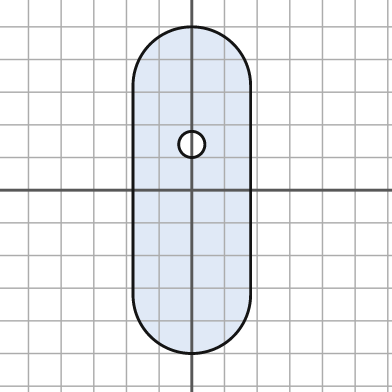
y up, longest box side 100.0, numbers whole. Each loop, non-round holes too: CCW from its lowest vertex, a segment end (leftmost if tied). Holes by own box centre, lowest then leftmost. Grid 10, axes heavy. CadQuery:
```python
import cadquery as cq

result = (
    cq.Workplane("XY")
    .moveTo(-18.0, -32.0)
    .threePointArc((0.0, -50.0), (18.0, -32.0))
    .lineTo(18.0, 32.0)
    .threePointArc((0.0, 50.0), (-18.0, 32.0))
    .close()
    .moveTo(0.0, 14.0)
    .circle(4.0)
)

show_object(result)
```